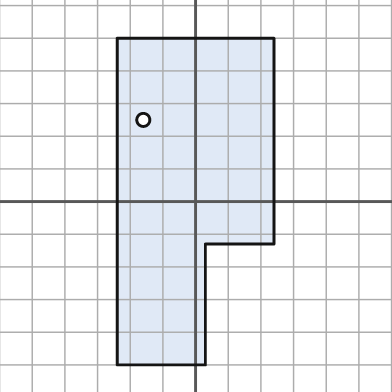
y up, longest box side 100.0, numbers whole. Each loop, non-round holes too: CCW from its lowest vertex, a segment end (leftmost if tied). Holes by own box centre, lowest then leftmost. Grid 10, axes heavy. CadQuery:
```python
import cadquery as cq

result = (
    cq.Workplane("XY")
    .moveTo(-24.0, -50.0)
    .lineTo(3.0, -50.0)
    .lineTo(3.0, -13.0)
    .lineTo(24.0, -13.0)
    .lineTo(24.0, 50.0)
    .lineTo(-24.0, 50.0)
    .close()
    .moveTo(-16.0, 25.0)
    .circle(2.0)
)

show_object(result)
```